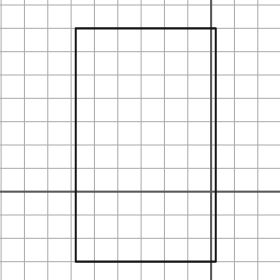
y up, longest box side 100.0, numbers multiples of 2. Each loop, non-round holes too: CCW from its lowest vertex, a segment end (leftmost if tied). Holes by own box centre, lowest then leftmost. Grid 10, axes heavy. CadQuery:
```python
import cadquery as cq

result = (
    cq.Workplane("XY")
    .moveTo(-58.0, -30.0)
    .lineTo(2.0, -30.0)
    .lineTo(2.0, 70.0)
    .lineTo(-58.0, 70.0)
    .close()
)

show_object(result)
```